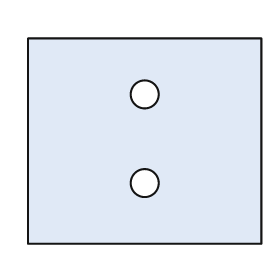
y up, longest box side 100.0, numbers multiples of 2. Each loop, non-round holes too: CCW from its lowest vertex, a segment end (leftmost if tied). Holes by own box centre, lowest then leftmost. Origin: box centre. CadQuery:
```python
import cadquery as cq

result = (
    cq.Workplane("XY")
    .moveTo(-50.0, -44.0)
    .lineTo(50.0, -44.0)
    .lineTo(50.0, 44.0)
    .lineTo(-50.0, 44.0)
    .close()
    .moveTo(0.0, -18.0)
    .circle(6.0)
    .moveTo(0.0, 20.0)
    .circle(6.0)
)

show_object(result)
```